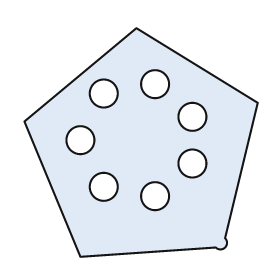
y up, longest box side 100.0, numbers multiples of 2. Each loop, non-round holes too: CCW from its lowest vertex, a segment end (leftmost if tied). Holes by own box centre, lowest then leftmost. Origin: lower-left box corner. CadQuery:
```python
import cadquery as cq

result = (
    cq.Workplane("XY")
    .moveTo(24.0, 0.0)
    .lineTo(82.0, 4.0)
    .threePointArc((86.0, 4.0), (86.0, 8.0))
    .lineTo(100.0, 66.0)
    .lineTo(48.0, 98.0)
    .lineTo(0.0, 58.0)
    .close()
    .moveTo(56.0, 26.0)
    .circle(6.0)
    .moveTo(34.0, 30.0)
    .circle(6.0)
    .moveTo(72.0, 40.0)
    .circle(6.0)
    .moveTo(24.0, 50.0)
    .circle(6.0)
    .moveTo(72.0, 60.0)
    .circle(6.0)
    .moveTo(34.0, 70.0)
    .circle(6.0)
    .moveTo(56.0, 74.0)
    .circle(6.0)
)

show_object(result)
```